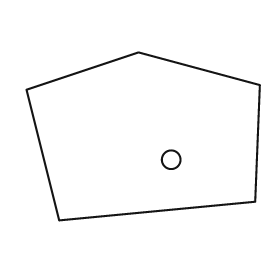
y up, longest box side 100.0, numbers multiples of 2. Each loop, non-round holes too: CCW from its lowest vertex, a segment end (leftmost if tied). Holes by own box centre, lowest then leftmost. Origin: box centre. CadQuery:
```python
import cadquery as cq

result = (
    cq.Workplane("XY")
    .moveTo(-36.0, -36.0)
    .lineTo(48.0, -28.0)
    .lineTo(50.0, 22.0)
    .lineTo(-2.0, 36.0)
    .lineTo(-50.0, 20.0)
    .close()
    .moveTo(12.0, -10.0)
    .circle(4.0)
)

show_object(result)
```